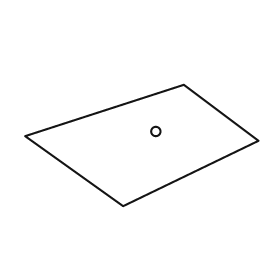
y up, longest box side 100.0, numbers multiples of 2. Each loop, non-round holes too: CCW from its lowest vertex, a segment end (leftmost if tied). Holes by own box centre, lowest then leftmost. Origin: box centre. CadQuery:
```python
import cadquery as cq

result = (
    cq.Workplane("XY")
    .moveTo(-8.0, -26.0)
    .lineTo(50.0, 2.0)
    .lineTo(18.0, 26.0)
    .lineTo(-50.0, 4.0)
    .close()
    .moveTo(6.0, 6.0)
    .circle(2.0)
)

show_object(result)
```